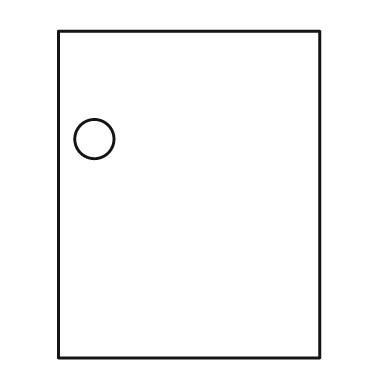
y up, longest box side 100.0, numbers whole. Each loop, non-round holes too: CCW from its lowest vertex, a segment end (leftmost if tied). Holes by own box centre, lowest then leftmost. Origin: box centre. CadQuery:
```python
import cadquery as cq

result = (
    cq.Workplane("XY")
    .moveTo(-40.0, -50.0)
    .lineTo(40.0, -50.0)
    .lineTo(40.0, 50.0)
    .lineTo(-40.0, 50.0)
    .close()
    .moveTo(-29.0, 17.0)
    .circle(6.0)
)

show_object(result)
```